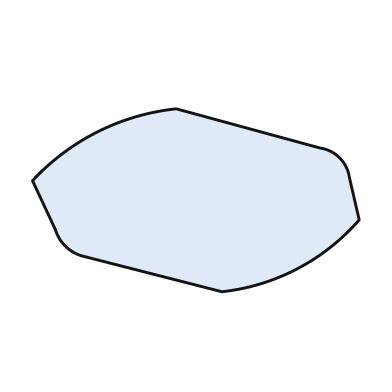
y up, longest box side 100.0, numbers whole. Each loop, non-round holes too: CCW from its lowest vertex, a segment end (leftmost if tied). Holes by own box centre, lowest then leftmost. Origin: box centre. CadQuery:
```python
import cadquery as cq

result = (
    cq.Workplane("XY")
    .moveTo(8.0, -28.0)
    .threePointArc((31.0, -21.0), (50.0, -6.0))
    .lineTo(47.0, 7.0)
    .threePointArc((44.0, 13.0), (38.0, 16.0))
    .lineTo(-6.0, 28.0)
    .threePointArc((-30.0, 21.0), (-50.0, 6.0))
    .lineTo(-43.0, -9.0)
    .threePointArc((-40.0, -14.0), (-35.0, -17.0))
    .close()
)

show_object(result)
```